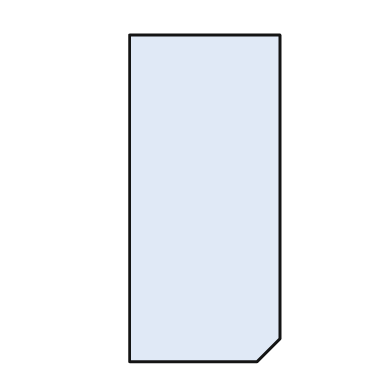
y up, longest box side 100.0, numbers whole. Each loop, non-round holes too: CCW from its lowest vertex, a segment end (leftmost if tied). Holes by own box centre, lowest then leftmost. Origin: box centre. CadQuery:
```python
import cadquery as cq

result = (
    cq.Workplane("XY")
    .moveTo(-23.0, -50.0)
    .lineTo(16.0, -50.0)
    .lineTo(23.0, -43.0)
    .lineTo(23.0, 50.0)
    .lineTo(-23.0, 50.0)
    .close()
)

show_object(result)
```